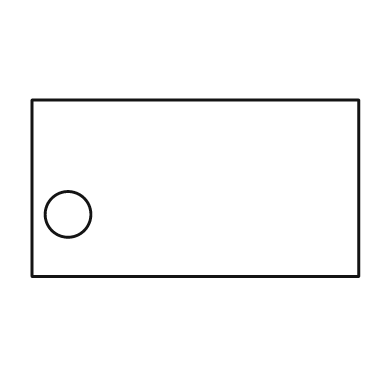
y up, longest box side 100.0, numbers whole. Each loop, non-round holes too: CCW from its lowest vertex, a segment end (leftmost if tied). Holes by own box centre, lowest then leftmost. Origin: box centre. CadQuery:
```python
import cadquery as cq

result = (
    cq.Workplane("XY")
    .moveTo(-50.0, -27.0)
    .lineTo(50.0, -27.0)
    .lineTo(50.0, 27.0)
    .lineTo(-50.0, 27.0)
    .close()
    .moveTo(-39.0, -8.0)
    .circle(7.0)
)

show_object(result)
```